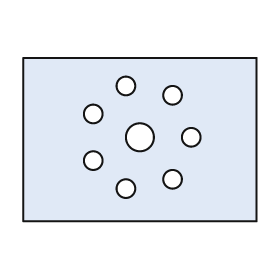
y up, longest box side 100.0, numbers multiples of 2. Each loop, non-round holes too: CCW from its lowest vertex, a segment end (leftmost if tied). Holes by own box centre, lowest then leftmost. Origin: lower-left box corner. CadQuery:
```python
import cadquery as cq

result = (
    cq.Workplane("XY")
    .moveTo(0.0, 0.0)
    .lineTo(100.0, 0.0)
    .lineTo(100.0, 70.0)
    .lineTo(0.0, 70.0)
    .close()
    .moveTo(44.0, 14.0)
    .circle(4.0)
    .moveTo(64.0, 18.0)
    .circle(4.0)
    .moveTo(30.0, 26.0)
    .circle(4.0)
    .moveTo(50.0, 36.0)
    .circle(6.0)
    .moveTo(72.0, 36.0)
    .circle(4.0)
    .moveTo(30.0, 46.0)
    .circle(4.0)
    .moveTo(64.0, 54.0)
    .circle(4.0)
    .moveTo(44.0, 58.0)
    .circle(4.0)
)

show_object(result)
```